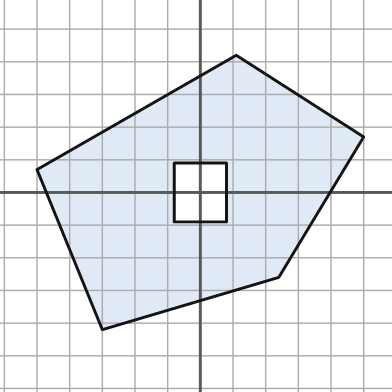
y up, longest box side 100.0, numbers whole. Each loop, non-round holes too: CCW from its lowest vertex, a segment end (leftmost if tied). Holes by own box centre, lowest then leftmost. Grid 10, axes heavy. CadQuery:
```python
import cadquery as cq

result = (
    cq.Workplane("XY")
    .moveTo(-30.0, -42.0)
    .lineTo(24.0, -26.0)
    .lineTo(50.0, 17.0)
    .lineTo(11.0, 42.0)
    .lineTo(-50.0, 7.0)
    .close()
    .moveTo(-8.0, -9.0)
    .lineTo(8.0, -9.0)
    .lineTo(8.0, 9.0)
    .lineTo(-8.0, 9.0)
    .close()
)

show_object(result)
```